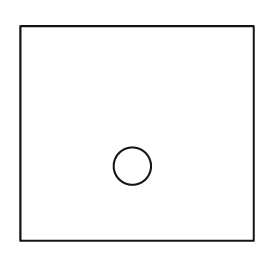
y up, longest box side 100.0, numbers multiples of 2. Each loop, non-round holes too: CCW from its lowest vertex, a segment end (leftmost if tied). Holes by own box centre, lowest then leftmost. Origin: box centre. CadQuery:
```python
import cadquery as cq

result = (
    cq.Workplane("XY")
    .moveTo(-50.0, -46.0)
    .lineTo(50.0, -46.0)
    .lineTo(50.0, 46.0)
    .lineTo(-50.0, 46.0)
    .close()
    .moveTo(-2.0, -14.0)
    .circle(8.0)
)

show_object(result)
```